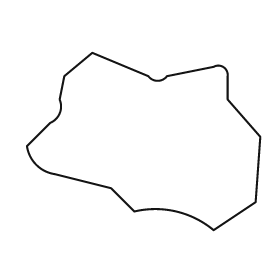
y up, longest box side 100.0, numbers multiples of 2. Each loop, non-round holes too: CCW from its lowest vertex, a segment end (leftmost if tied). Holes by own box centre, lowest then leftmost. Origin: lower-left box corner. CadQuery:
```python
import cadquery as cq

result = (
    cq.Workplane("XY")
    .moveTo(80.0, 0.0)
    .lineTo(98.0, 12.0)
    .lineTo(100.0, 40.0)
    .lineTo(86.0, 56.0)
    .lineTo(86.0, 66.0)
    .threePointArc((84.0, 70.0), (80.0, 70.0))
    .lineTo(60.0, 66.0)
    .threePointArc((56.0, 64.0), (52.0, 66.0))
    .lineTo(28.0, 76.0)
    .lineTo(16.0, 66.0)
    .lineTo(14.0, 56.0)
    .threePointArc((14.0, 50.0), (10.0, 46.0))
    .lineTo(0.0, 36.0)
    .threePointArc((4.0, 28.0), (12.0, 24.0))
    .lineTo(36.0, 18.0)
    .lineTo(46.0, 8.0)
    .threePointArc((64.0, 8.0), (80.0, 0.0))
    .close()
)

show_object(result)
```